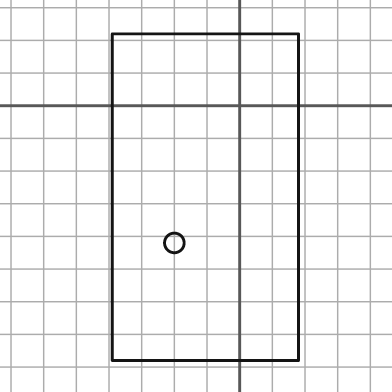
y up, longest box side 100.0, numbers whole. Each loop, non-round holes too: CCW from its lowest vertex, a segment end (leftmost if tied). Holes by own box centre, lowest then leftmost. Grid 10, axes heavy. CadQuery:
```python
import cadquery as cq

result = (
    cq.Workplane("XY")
    .moveTo(-39.0, -78.0)
    .lineTo(18.0, -78.0)
    .lineTo(18.0, 22.0)
    .lineTo(-39.0, 22.0)
    .close()
    .moveTo(-20.0, -42.0)
    .circle(3.0)
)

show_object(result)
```